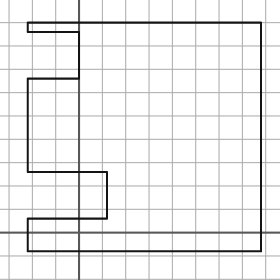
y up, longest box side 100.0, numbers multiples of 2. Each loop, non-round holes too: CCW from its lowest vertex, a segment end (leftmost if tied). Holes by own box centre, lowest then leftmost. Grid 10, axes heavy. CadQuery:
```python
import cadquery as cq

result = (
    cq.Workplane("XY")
    .moveTo(-22.0, -8.0)
    .lineTo(78.0, -8.0)
    .lineTo(78.0, 90.0)
    .lineTo(-22.0, 90.0)
    .lineTo(-22.0, 86.0)
    .lineTo(0.0, 86.0)
    .lineTo(0.0, 66.0)
    .lineTo(-22.0, 66.0)
    .lineTo(-22.0, 26.0)
    .lineTo(12.0, 26.0)
    .lineTo(12.0, 6.0)
    .lineTo(-22.0, 6.0)
    .close()
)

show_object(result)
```